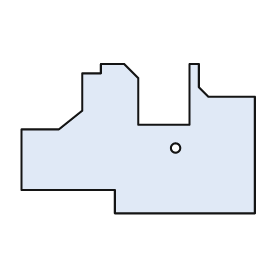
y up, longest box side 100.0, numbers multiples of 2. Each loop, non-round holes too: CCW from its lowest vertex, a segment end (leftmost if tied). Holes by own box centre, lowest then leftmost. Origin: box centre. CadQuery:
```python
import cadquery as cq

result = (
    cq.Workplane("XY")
    .moveTo(-10.0, -32.0)
    .lineTo(50.0, -32.0)
    .lineTo(50.0, 18.0)
    .lineTo(30.0, 18.0)
    .lineTo(26.0, 22.0)
    .lineTo(26.0, 32.0)
    .lineTo(22.0, 32.0)
    .lineTo(22.0, 6.0)
    .lineTo(0.0, 6.0)
    .lineTo(0.0, 26.0)
    .lineTo(-6.0, 32.0)
    .lineTo(-16.0, 32.0)
    .lineTo(-16.0, 28.0)
    .lineTo(-24.0, 28.0)
    .lineTo(-24.0, 12.0)
    .lineTo(-34.0, 4.0)
    .lineTo(-50.0, 4.0)
    .lineTo(-50.0, -22.0)
    .lineTo(-10.0, -22.0)
    .close()
    .moveTo(16.0, -4.0)
    .circle(2.0)
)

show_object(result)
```